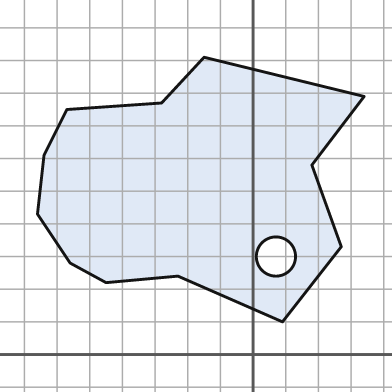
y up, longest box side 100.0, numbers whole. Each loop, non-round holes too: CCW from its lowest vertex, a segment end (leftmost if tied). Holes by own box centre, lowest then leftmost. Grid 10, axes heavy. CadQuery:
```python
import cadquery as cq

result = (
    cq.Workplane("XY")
    .moveTo(9.0, 10.0)
    .lineTo(27.0, 33.0)
    .lineTo(18.0, 58.0)
    .lineTo(34.0, 79.0)
    .lineTo(-15.0, 91.0)
    .lineTo(-28.0, 77.0)
    .lineTo(-57.0, 75.0)
    .lineTo(-64.0, 61.0)
    .lineTo(-66.0, 43.0)
    .lineTo(-56.0, 28.0)
    .lineTo(-45.0, 22.0)
    .lineTo(-23.0, 24.0)
    .close()
    .moveTo(7.0, 30.0)
    .circle(6.0)
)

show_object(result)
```